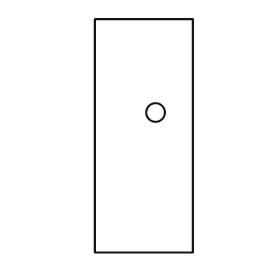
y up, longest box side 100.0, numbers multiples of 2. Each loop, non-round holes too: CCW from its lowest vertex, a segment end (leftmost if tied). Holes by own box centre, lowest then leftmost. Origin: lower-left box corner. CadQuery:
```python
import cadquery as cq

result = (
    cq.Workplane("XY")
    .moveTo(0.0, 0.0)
    .lineTo(42.0, 0.0)
    .lineTo(42.0, 100.0)
    .lineTo(0.0, 100.0)
    .close()
    .moveTo(26.0, 60.0)
    .circle(4.0)
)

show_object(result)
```